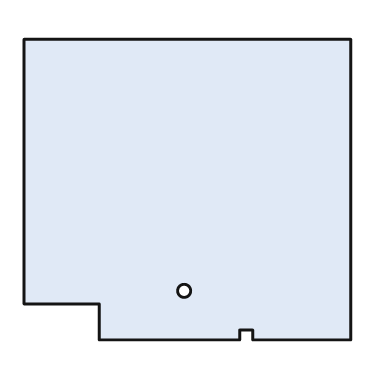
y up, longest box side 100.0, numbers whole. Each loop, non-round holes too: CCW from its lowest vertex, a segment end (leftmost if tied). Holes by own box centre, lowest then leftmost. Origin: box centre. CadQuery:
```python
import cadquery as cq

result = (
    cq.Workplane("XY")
    .moveTo(-27.0, -46.0)
    .lineTo(16.0, -46.0)
    .lineTo(16.0, -43.0)
    .lineTo(20.0, -43.0)
    .lineTo(20.0, -46.0)
    .lineTo(50.0, -46.0)
    .lineTo(50.0, 46.0)
    .lineTo(-50.0, 46.0)
    .lineTo(-50.0, -35.0)
    .lineTo(-27.0, -35.0)
    .close()
    .moveTo(-1.0, -31.0)
    .circle(2.0)
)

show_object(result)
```